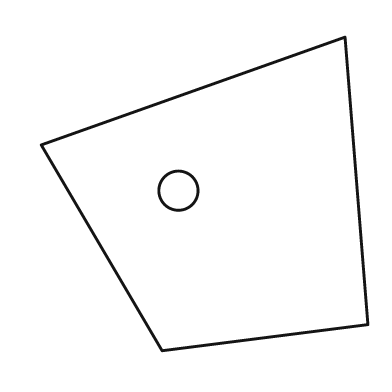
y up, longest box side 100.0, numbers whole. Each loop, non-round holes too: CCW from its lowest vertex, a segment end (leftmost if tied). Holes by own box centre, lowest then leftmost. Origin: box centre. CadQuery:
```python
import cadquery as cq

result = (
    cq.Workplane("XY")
    .moveTo(-13.0, -48.0)
    .lineTo(50.0, -40.0)
    .lineTo(43.0, 48.0)
    .lineTo(-50.0, 15.0)
    .close()
    .moveTo(-8.0, 1.0)
    .circle(6.0)
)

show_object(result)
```